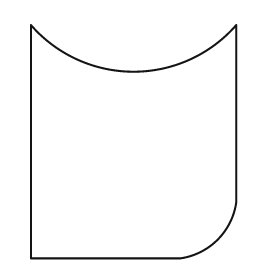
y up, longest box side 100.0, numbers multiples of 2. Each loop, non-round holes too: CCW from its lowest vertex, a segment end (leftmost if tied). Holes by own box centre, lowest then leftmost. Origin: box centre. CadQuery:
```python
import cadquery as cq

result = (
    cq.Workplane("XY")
    .moveTo(-44.0, -50.0)
    .lineTo(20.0, -50.0)
    .threePointArc((36.0, -42.0), (44.0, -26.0))
    .lineTo(44.0, 50.0)
    .threePointArc((0.0, 30.0), (-44.0, 50.0))
    .close()
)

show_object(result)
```